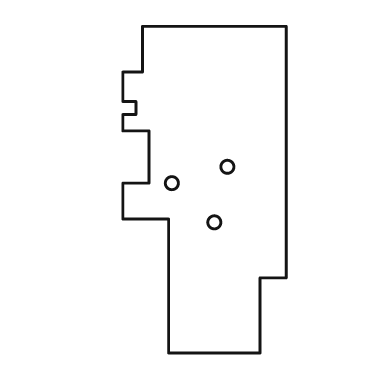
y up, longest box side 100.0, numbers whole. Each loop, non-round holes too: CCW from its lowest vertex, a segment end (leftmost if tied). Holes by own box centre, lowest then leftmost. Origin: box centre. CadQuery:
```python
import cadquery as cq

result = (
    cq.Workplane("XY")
    .moveTo(-11.0, -50.0)
    .lineTo(17.0, -50.0)
    .lineTo(17.0, -27.0)
    .lineTo(25.0, -27.0)
    .lineTo(25.0, 50.0)
    .lineTo(-19.0, 50.0)
    .lineTo(-19.0, 36.0)
    .lineTo(-25.0, 36.0)
    .lineTo(-25.0, 27.0)
    .lineTo(-21.0, 27.0)
    .lineTo(-21.0, 23.0)
    .lineTo(-25.0, 23.0)
    .lineTo(-25.0, 18.0)
    .lineTo(-17.0, 18.0)
    .lineTo(-17.0, 2.0)
    .lineTo(-25.0, 2.0)
    .lineTo(-25.0, -9.0)
    .lineTo(-11.0, -9.0)
    .close()
    .moveTo(3.0, -10.0)
    .circle(2.0)
    .moveTo(-10.0, 2.0)
    .circle(2.0)
    .moveTo(7.0, 7.0)
    .circle(2.0)
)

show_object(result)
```